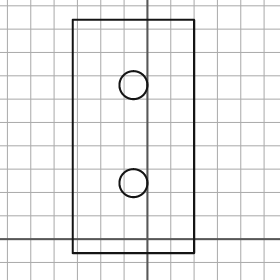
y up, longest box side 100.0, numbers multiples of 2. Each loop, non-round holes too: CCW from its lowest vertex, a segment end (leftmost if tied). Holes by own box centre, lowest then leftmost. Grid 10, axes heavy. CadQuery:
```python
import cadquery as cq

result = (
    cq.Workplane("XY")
    .moveTo(-32.0, -6.0)
    .lineTo(20.0, -6.0)
    .lineTo(20.0, 94.0)
    .lineTo(-32.0, 94.0)
    .close()
    .moveTo(-6.0, 24.0)
    .circle(6.0)
    .moveTo(-6.0, 66.0)
    .circle(6.0)
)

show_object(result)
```